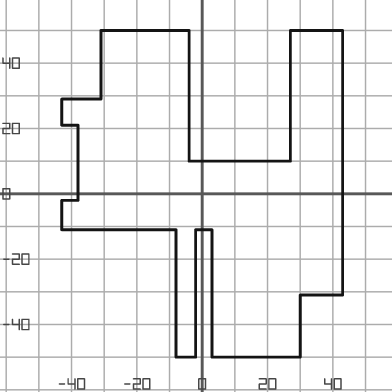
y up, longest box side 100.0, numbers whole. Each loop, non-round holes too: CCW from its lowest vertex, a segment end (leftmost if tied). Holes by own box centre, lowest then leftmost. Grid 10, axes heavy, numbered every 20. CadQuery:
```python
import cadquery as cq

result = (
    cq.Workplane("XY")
    .moveTo(-8.0, -50.0)
    .lineTo(-2.0, -50.0)
    .lineTo(-2.0, -11.0)
    .lineTo(3.0, -11.0)
    .lineTo(3.0, -50.0)
    .lineTo(30.0, -50.0)
    .lineTo(30.0, -31.0)
    .lineTo(43.0, -31.0)
    .lineTo(43.0, 50.0)
    .lineTo(27.0, 50.0)
    .lineTo(27.0, 10.0)
    .lineTo(-4.0, 10.0)
    .lineTo(-4.0, 50.0)
    .lineTo(-31.0, 50.0)
    .lineTo(-31.0, 29.0)
    .lineTo(-43.0, 29.0)
    .lineTo(-43.0, 21.0)
    .lineTo(-38.0, 21.0)
    .lineTo(-38.0, -2.0)
    .lineTo(-43.0, -2.0)
    .lineTo(-43.0, -11.0)
    .lineTo(-8.0, -11.0)
    .close()
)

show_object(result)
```